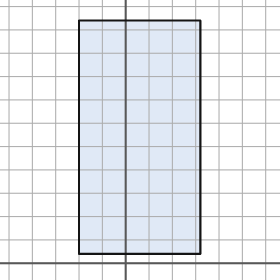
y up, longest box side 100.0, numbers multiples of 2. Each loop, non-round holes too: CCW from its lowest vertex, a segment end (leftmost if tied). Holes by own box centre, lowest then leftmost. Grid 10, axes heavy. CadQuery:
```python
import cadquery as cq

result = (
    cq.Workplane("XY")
    .moveTo(-20.0, 4.0)
    .lineTo(32.0, 4.0)
    .lineTo(32.0, 104.0)
    .lineTo(-20.0, 104.0)
    .close()
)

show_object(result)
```